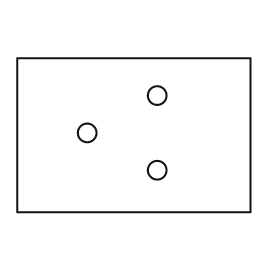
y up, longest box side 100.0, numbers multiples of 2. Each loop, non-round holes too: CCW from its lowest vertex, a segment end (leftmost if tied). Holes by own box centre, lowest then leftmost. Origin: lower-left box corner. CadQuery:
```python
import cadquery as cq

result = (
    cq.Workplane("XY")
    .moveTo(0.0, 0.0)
    .lineTo(100.0, 0.0)
    .lineTo(100.0, 66.0)
    .lineTo(0.0, 66.0)
    .close()
    .moveTo(60.0, 18.0)
    .circle(4.0)
    .moveTo(30.0, 34.0)
    .circle(4.0)
    .moveTo(60.0, 50.0)
    .circle(4.0)
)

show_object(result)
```